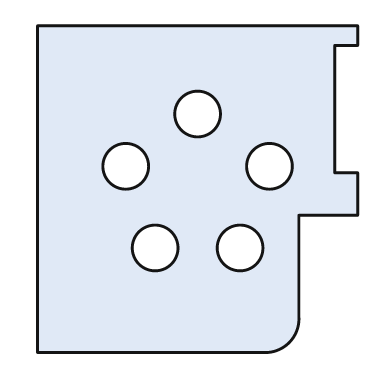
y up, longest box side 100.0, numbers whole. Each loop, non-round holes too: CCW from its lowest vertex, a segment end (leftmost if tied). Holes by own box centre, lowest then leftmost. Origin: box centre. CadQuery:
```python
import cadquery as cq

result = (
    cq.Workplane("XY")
    .moveTo(-49.0, -50.0)
    .lineTo(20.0, -50.0)
    .threePointArc((28.0, -47.0), (31.0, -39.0))
    .lineTo(31.0, -8.0)
    .lineTo(49.0, -8.0)
    .lineTo(49.0, 5.0)
    .lineTo(42.0, 5.0)
    .lineTo(42.0, 44.0)
    .lineTo(49.0, 44.0)
    .lineTo(49.0, 50.0)
    .lineTo(-49.0, 50.0)
    .close()
    .moveTo(-13.0, -18.0)
    .circle(7.0)
    .moveTo(13.0, -18.0)
    .circle(7.0)
    .moveTo(-22.0, 7.0)
    .circle(7.0)
    .moveTo(22.0, 7.0)
    .circle(7.0)
    .moveTo(0.0, 23.0)
    .circle(7.0)
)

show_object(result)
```